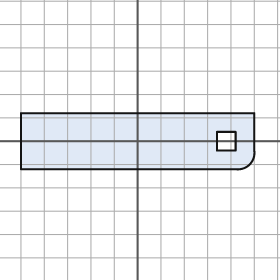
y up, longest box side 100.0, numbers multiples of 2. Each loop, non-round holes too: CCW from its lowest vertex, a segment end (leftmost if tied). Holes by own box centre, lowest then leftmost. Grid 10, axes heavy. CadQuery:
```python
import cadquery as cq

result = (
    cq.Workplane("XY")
    .moveTo(-50.0, -12.0)
    .lineTo(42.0, -12.0)
    .threePointArc((48.0, -10.0), (50.0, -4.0))
    .lineTo(50.0, 12.0)
    .lineTo(-50.0, 12.0)
    .close()
    .moveTo(34.0, -4.0)
    .lineTo(42.0, -4.0)
    .lineTo(42.0, 4.0)
    .lineTo(34.0, 4.0)
    .close()
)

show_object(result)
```